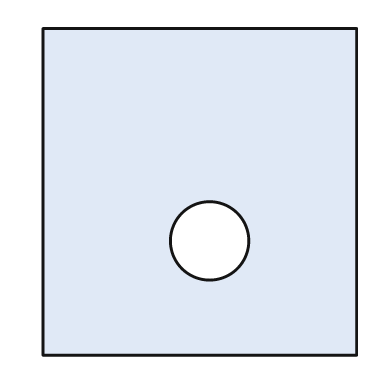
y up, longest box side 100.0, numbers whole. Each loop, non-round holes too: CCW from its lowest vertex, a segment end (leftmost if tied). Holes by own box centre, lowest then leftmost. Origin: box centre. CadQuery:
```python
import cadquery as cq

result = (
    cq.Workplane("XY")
    .moveTo(-48.0, -50.0)
    .lineTo(48.0, -50.0)
    .lineTo(48.0, 50.0)
    .lineTo(-48.0, 50.0)
    .close()
    .moveTo(3.0, -15.0)
    .circle(12.0)
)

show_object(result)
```